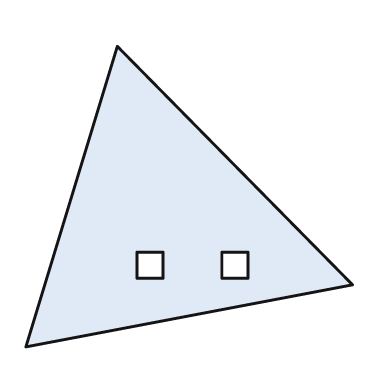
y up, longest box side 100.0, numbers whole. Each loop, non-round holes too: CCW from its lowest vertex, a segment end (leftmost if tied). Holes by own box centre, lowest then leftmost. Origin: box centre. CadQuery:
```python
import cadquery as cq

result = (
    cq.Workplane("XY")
    .moveTo(-50.0, -46.0)
    .lineTo(50.0, -27.0)
    .lineTo(-22.0, 46.0)
    .close()
    .moveTo(-16.0, -25.0)
    .lineTo(-8.0, -25.0)
    .lineTo(-8.0, -17.0)
    .lineTo(-16.0, -17.0)
    .close()
    .moveTo(10.0, -25.0)
    .lineTo(18.0, -25.0)
    .lineTo(18.0, -17.0)
    .lineTo(10.0, -17.0)
    .close()
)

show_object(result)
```